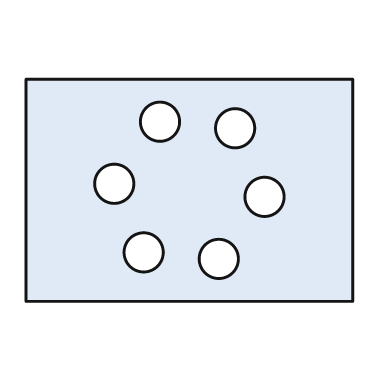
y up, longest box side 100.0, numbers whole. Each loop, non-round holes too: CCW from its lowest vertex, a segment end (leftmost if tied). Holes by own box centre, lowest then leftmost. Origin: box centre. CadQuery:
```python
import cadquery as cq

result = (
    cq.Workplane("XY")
    .moveTo(-50.0, -34.0)
    .lineTo(50.0, -34.0)
    .lineTo(50.0, 34.0)
    .lineTo(-50.0, 34.0)
    .close()
    .moveTo(9.0, -21.0)
    .circle(6.0)
    .moveTo(-14.0, -19.0)
    .circle(6.0)
    .moveTo(23.0, -2.0)
    .circle(6.0)
    .moveTo(-23.0, 2.0)
    .circle(6.0)
    .moveTo(14.0, 19.0)
    .circle(6.0)
    .moveTo(-9.0, 21.0)
    .circle(6.0)
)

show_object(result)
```